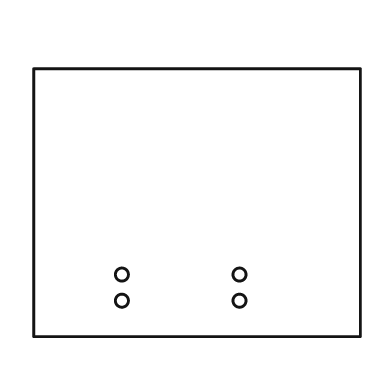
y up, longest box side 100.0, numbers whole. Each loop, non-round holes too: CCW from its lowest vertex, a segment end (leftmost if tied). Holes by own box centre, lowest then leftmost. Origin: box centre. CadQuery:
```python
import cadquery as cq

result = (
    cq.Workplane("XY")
    .moveTo(-50.0, -41.0)
    .lineTo(50.0, -41.0)
    .lineTo(50.0, 41.0)
    .lineTo(-50.0, 41.0)
    .close()
    .moveTo(-23.0, -30.0)
    .circle(2.0)
    .moveTo(13.0, -30.0)
    .circle(2.0)
    .moveTo(-23.0, -22.0)
    .circle(2.0)
    .moveTo(13.0, -22.0)
    .circle(2.0)
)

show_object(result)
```